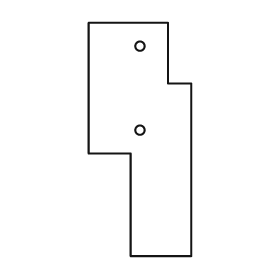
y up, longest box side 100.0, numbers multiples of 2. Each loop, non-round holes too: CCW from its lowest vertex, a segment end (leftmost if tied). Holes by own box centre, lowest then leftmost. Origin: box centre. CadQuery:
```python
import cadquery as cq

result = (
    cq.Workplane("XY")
    .moveTo(-4.0, -50.0)
    .lineTo(22.0, -50.0)
    .lineTo(22.0, 24.0)
    .lineTo(12.0, 24.0)
    .lineTo(12.0, 50.0)
    .lineTo(-22.0, 50.0)
    .lineTo(-22.0, -6.0)
    .lineTo(-4.0, -6.0)
    .close()
    .moveTo(0.0, 4.0)
    .circle(2.0)
    .moveTo(0.0, 40.0)
    .circle(2.0)
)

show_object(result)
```